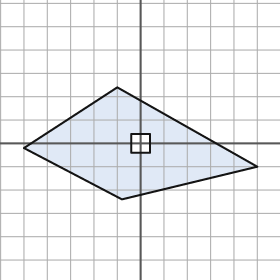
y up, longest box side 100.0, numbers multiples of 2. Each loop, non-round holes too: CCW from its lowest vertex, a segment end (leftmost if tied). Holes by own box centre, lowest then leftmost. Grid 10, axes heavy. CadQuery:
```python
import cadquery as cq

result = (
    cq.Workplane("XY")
    .moveTo(-8.0, -24.0)
    .lineTo(50.0, -10.0)
    .lineTo(-10.0, 24.0)
    .lineTo(-50.0, -2.0)
    .close()
    .moveTo(-4.0, -4.0)
    .lineTo(4.0, -4.0)
    .lineTo(4.0, 4.0)
    .lineTo(-4.0, 4.0)
    .close()
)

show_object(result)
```